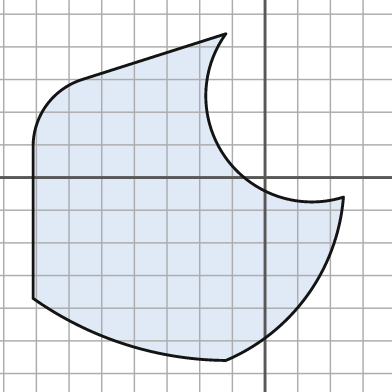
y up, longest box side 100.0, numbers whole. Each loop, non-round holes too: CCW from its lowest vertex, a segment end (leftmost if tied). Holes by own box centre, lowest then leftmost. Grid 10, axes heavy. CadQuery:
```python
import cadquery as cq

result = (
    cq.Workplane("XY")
    .moveTo(-12.0, -56.0)
    .threePointArc((13.0, -36.0), (24.0, -6.0))
    .threePointArc((-12.0, 6.0), (-12.0, 44.0))
    .lineTo(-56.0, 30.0)
    .threePointArc((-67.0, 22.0), (-71.0, 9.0))
    .lineTo(-71.0, -37.0)
    .threePointArc((-43.0, -51.0), (-12.0, -56.0))
    .close()
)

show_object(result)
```